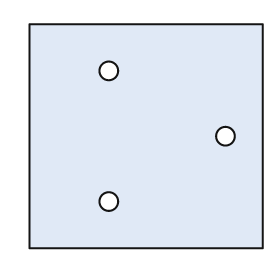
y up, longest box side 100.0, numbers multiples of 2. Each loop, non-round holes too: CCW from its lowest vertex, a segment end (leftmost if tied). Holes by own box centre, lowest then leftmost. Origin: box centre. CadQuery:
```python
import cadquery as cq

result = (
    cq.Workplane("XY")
    .moveTo(-50.0, -48.0)
    .lineTo(50.0, -48.0)
    .lineTo(50.0, 48.0)
    .lineTo(-50.0, 48.0)
    .close()
    .moveTo(-16.0, -28.0)
    .circle(4.0)
    .moveTo(34.0, 0.0)
    .circle(4.0)
    .moveTo(-16.0, 28.0)
    .circle(4.0)
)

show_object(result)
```